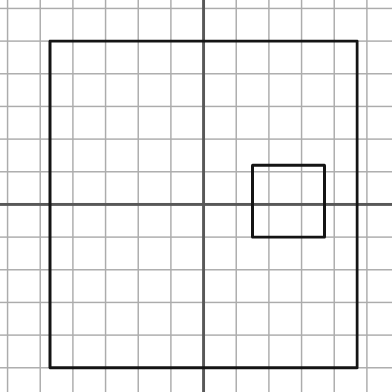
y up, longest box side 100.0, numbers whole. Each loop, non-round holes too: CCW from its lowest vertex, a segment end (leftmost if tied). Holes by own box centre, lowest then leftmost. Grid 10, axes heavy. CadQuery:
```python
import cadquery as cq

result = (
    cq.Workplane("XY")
    .moveTo(-47.0, -50.0)
    .lineTo(47.0, -50.0)
    .lineTo(47.0, 50.0)
    .lineTo(-47.0, 50.0)
    .close()
    .moveTo(15.0, -10.0)
    .lineTo(37.0, -10.0)
    .lineTo(37.0, 12.0)
    .lineTo(15.0, 12.0)
    .close()
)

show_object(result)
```